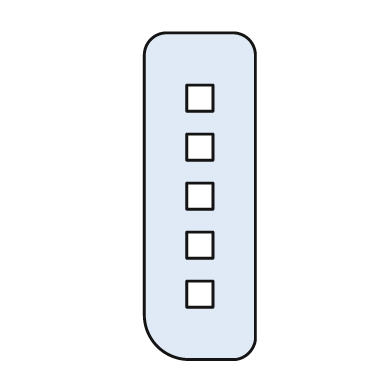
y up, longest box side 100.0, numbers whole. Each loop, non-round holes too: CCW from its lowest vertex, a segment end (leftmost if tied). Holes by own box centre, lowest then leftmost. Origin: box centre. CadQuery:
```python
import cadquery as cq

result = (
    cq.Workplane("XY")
    .moveTo(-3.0, -50.0)
    .lineTo(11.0, -50.0)
    .threePointArc((15.0, -48.0), (17.0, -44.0))
    .lineTo(17.0, 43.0)
    .threePointArc((15.0, 48.0), (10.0, 50.0))
    .lineTo(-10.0, 50.0)
    .threePointArc((-15.0, 48.0), (-17.0, 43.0))
    .lineTo(-17.0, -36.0)
    .threePointArc((-13.0, -46.0), (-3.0, -50.0))
    .close()
    .moveTo(-4.0, -34.0)
    .lineTo(4.0, -34.0)
    .lineTo(4.0, -26.0)
    .lineTo(-4.0, -26.0)
    .close()
    .moveTo(-4.0, -19.0)
    .lineTo(4.0, -19.0)
    .lineTo(4.0, -11.0)
    .lineTo(-4.0, -11.0)
    .close()
    .moveTo(-4.0, -4.0)
    .lineTo(4.0, -4.0)
    .lineTo(4.0, 4.0)
    .lineTo(-4.0, 4.0)
    .close()
    .moveTo(-4.0, 11.0)
    .lineTo(4.0, 11.0)
    .lineTo(4.0, 19.0)
    .lineTo(-4.0, 19.0)
    .close()
    .moveTo(-4.0, 26.0)
    .lineTo(4.0, 26.0)
    .lineTo(4.0, 34.0)
    .lineTo(-4.0, 34.0)
    .close()
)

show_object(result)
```